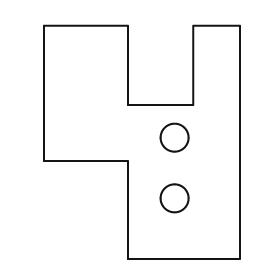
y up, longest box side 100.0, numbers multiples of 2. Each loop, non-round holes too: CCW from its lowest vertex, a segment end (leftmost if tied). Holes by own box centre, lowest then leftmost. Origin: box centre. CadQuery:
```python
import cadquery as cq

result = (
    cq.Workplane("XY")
    .moveTo(-6.0, -50.0)
    .lineTo(42.0, -50.0)
    .lineTo(42.0, 50.0)
    .lineTo(22.0, 50.0)
    .lineTo(22.0, 16.0)
    .lineTo(-6.0, 16.0)
    .lineTo(-6.0, 50.0)
    .lineTo(-42.0, 50.0)
    .lineTo(-42.0, -8.0)
    .lineTo(-6.0, -8.0)
    .close()
    .moveTo(14.0, -24.0)
    .circle(6.0)
    .moveTo(14.0, 2.0)
    .circle(6.0)
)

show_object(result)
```